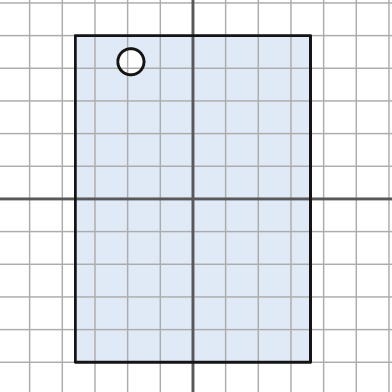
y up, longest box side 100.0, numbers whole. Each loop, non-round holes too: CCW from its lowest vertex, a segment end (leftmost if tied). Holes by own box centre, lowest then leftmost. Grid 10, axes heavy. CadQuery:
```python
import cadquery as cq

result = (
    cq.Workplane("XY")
    .moveTo(-36.0, -50.0)
    .lineTo(36.0, -50.0)
    .lineTo(36.0, 50.0)
    .lineTo(-36.0, 50.0)
    .close()
    .moveTo(-19.0, 42.0)
    .circle(4.0)
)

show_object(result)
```